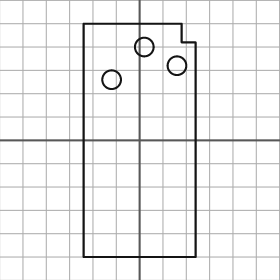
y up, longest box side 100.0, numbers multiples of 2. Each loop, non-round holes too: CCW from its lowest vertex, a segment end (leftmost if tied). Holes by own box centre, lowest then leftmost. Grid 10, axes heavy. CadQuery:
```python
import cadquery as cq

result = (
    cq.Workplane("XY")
    .moveTo(-24.0, -50.0)
    .lineTo(24.0, -50.0)
    .lineTo(24.0, 42.0)
    .lineTo(18.0, 42.0)
    .lineTo(18.0, 50.0)
    .lineTo(-24.0, 50.0)
    .close()
    .moveTo(-12.0, 26.0)
    .circle(4.0)
    .moveTo(16.0, 32.0)
    .circle(4.0)
    .moveTo(2.0, 40.0)
    .circle(4.0)
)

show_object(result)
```